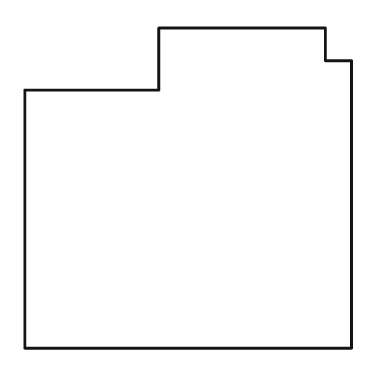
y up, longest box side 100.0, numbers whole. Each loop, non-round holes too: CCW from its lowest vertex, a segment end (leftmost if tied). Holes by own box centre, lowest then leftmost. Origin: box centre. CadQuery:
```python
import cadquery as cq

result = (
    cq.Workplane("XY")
    .moveTo(-50.0, -49.0)
    .lineTo(50.0, -49.0)
    .lineTo(50.0, 39.0)
    .lineTo(42.0, 39.0)
    .lineTo(42.0, 49.0)
    .lineTo(-9.0, 49.0)
    .lineTo(-9.0, 30.0)
    .lineTo(-50.0, 30.0)
    .close()
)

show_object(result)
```